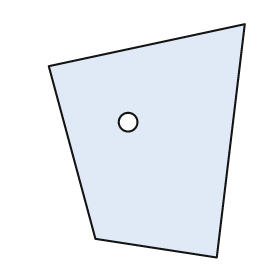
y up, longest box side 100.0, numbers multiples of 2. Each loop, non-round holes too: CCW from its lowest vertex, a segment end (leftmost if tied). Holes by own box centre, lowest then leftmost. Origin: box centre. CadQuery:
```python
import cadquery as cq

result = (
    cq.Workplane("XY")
    .moveTo(30.0, -50.0)
    .lineTo(42.0, 50.0)
    .lineTo(-42.0, 32.0)
    .lineTo(-22.0, -42.0)
    .close()
    .moveTo(-8.0, 8.0)
    .circle(4.0)
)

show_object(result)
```